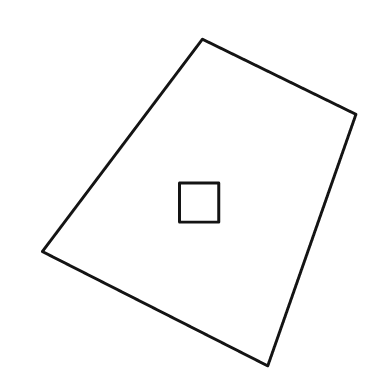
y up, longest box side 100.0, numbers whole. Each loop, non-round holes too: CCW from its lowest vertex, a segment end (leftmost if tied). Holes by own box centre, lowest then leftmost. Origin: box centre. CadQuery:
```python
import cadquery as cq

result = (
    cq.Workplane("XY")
    .moveTo(21.0, -50.0)
    .lineTo(48.0, 27.0)
    .lineTo(1.0, 50.0)
    .lineTo(-48.0, -15.0)
    .close()
    .moveTo(-6.0, -6.0)
    .lineTo(6.0, -6.0)
    .lineTo(6.0, 6.0)
    .lineTo(-6.0, 6.0)
    .close()
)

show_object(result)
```